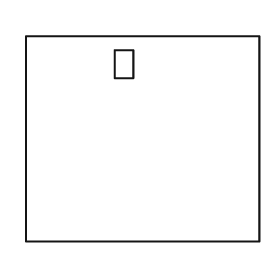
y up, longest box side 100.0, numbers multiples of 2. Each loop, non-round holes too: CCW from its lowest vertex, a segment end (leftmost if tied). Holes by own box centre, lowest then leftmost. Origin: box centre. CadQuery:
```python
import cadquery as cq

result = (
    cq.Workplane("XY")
    .moveTo(-50.0, -44.0)
    .lineTo(50.0, -44.0)
    .lineTo(50.0, 44.0)
    .lineTo(-50.0, 44.0)
    .close()
    .moveTo(-12.0, 26.0)
    .lineTo(-4.0, 26.0)
    .lineTo(-4.0, 38.0)
    .lineTo(-12.0, 38.0)
    .close()
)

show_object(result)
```